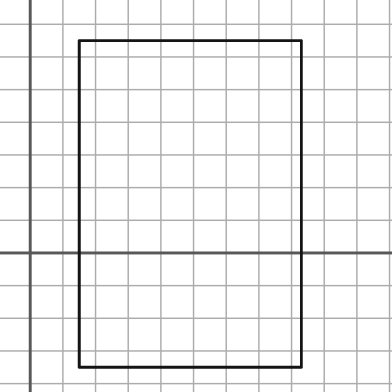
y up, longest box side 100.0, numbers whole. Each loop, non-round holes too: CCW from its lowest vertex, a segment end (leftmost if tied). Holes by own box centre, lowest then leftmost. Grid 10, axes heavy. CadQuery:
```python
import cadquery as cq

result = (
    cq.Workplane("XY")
    .moveTo(15.0, -35.0)
    .lineTo(83.0, -35.0)
    .lineTo(83.0, 65.0)
    .lineTo(15.0, 65.0)
    .close()
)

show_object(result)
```